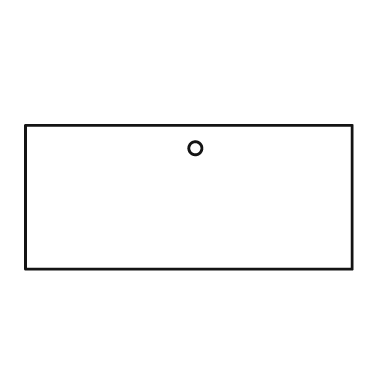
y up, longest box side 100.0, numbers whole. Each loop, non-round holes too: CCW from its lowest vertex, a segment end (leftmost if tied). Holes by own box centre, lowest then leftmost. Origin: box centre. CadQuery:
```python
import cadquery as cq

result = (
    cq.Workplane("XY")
    .moveTo(-50.0, -22.0)
    .lineTo(50.0, -22.0)
    .lineTo(50.0, 22.0)
    .lineTo(-50.0, 22.0)
    .close()
    .moveTo(2.0, 15.0)
    .circle(2.0)
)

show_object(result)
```